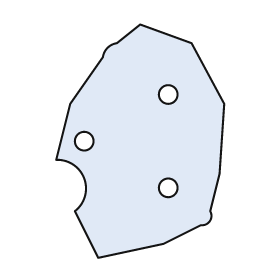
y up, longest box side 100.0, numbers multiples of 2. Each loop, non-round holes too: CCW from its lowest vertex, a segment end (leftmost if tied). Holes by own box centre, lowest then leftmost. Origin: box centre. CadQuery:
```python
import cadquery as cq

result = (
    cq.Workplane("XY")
    .moveTo(-18.0, -50.0)
    .lineTo(10.0, -44.0)
    .lineTo(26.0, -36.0)
    .threePointArc((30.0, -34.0), (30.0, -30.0))
    .lineTo(34.0, -14.0)
    .lineTo(36.0, 16.0)
    .lineTo(22.0, 42.0)
    .lineTo(0.0, 50.0)
    .lineTo(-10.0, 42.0)
    .threePointArc((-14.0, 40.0), (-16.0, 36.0))
    .lineTo(-30.0, 16.0)
    .lineTo(-36.0, -8.0)
    .threePointArc((-24.0, -16.0), (-28.0, -30.0))
    .close()
    .moveTo(12.0, -20.0)
    .circle(4.0)
    .moveTo(-24.0, 0.0)
    .circle(4.0)
    .moveTo(12.0, 20.0)
    .circle(4.0)
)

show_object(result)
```